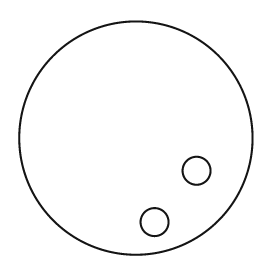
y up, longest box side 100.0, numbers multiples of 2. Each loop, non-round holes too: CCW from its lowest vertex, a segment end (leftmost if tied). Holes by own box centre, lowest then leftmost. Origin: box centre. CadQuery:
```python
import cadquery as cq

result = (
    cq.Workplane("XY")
    .moveTo(0.0, 0.0)
    .circle(50.0)
    .moveTo(8.0, -36.0)
    .circle(6.0)
    .moveTo(26.0, -14.0)
    .circle(6.0)
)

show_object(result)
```